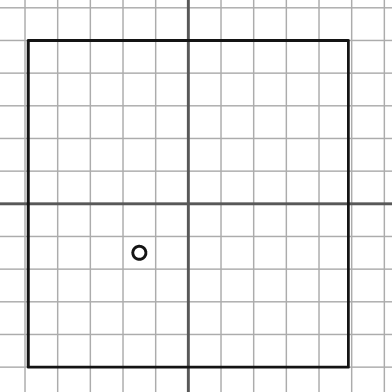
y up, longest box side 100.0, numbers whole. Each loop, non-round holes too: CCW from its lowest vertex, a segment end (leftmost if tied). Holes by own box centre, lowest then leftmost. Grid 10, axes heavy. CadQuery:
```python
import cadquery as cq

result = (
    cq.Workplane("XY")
    .moveTo(-49.0, -50.0)
    .lineTo(49.0, -50.0)
    .lineTo(49.0, 50.0)
    .lineTo(-49.0, 50.0)
    .close()
    .moveTo(-15.0, -15.0)
    .circle(2.0)
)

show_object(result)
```